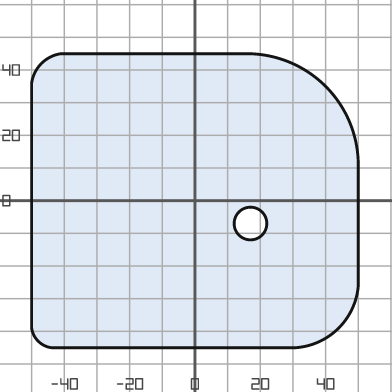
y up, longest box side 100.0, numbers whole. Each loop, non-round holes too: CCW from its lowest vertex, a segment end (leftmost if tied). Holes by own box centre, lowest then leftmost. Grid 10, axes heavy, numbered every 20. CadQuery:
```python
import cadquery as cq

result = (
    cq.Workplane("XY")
    .moveTo(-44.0, -45.0)
    .lineTo(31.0, -45.0)
    .threePointArc((44.0, -39.0), (50.0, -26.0))
    .lineTo(50.0, 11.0)
    .threePointArc((40.0, 35.0), (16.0, 45.0))
    .lineTo(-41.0, 45.0)
    .threePointArc((-47.0, 42.0), (-50.0, 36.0))
    .lineTo(-50.0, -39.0)
    .threePointArc((-48.0, -43.0), (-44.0, -45.0))
    .close()
    .moveTo(17.0, -7.0)
    .circle(5.0)
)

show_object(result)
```